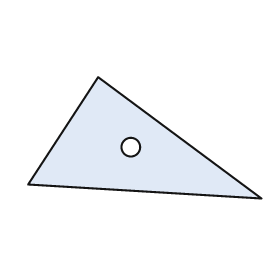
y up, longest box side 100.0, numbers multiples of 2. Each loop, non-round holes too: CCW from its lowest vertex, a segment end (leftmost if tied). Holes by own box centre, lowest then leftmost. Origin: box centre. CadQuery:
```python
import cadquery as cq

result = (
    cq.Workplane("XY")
    .moveTo(50.0, -26.0)
    .lineTo(-20.0, 26.0)
    .lineTo(-50.0, -20.0)
    .close()
    .moveTo(-6.0, -4.0)
    .circle(4.0)
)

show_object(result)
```